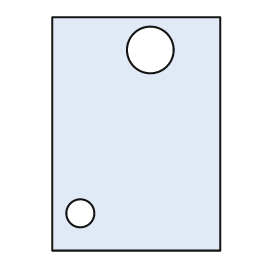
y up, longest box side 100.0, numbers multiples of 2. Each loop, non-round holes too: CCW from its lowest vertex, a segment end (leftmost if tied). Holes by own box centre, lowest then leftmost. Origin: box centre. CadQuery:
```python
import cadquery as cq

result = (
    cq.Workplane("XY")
    .moveTo(-36.0, -50.0)
    .lineTo(36.0, -50.0)
    .lineTo(36.0, 50.0)
    .lineTo(-36.0, 50.0)
    .close()
    .moveTo(-24.0, -34.0)
    .circle(6.0)
    .moveTo(6.0, 36.0)
    .circle(10.0)
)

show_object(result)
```